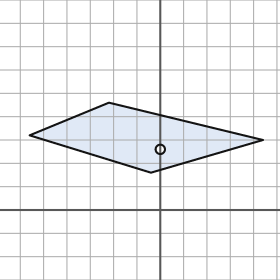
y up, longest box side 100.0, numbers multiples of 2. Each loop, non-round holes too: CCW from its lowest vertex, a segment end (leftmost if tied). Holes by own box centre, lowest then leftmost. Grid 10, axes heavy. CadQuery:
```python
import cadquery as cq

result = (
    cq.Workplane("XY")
    .moveTo(-4.0, 16.0)
    .lineTo(44.0, 30.0)
    .lineTo(-22.0, 46.0)
    .lineTo(-56.0, 32.0)
    .close()
    .moveTo(0.0, 26.0)
    .circle(2.0)
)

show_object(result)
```